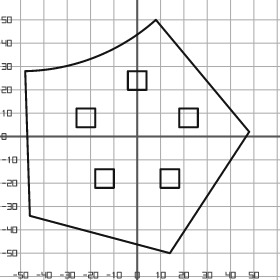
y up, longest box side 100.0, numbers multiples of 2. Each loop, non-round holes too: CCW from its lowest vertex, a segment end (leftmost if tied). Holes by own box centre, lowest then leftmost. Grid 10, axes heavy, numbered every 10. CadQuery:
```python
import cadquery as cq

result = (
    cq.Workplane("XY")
    .moveTo(14.0, -50.0)
    .lineTo(48.0, 2.0)
    .lineTo(8.0, 50.0)
    .threePointArc((-18.0, 34.0), (-48.0, 28.0))
    .lineTo(-46.0, -34.0)
    .close()
    .moveTo(-18.0, -22.0)
    .lineTo(-10.0, -22.0)
    .lineTo(-10.0, -14.0)
    .lineTo(-18.0, -14.0)
    .close()
    .moveTo(10.0, -22.0)
    .lineTo(18.0, -22.0)
    .lineTo(18.0, -14.0)
    .lineTo(10.0, -14.0)
    .close()
    .moveTo(-26.0, 4.0)
    .lineTo(-18.0, 4.0)
    .lineTo(-18.0, 12.0)
    .lineTo(-26.0, 12.0)
    .close()
    .moveTo(18.0, 4.0)
    .lineTo(26.0, 4.0)
    .lineTo(26.0, 12.0)
    .lineTo(18.0, 12.0)
    .close()
    .moveTo(-4.0, 20.0)
    .lineTo(4.0, 20.0)
    .lineTo(4.0, 28.0)
    .lineTo(-4.0, 28.0)
    .close()
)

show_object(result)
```